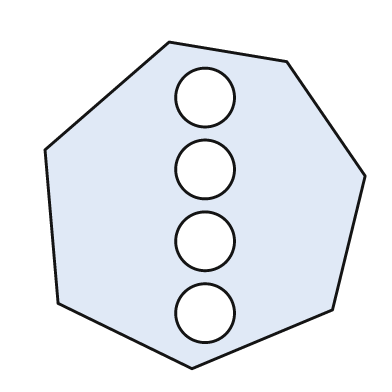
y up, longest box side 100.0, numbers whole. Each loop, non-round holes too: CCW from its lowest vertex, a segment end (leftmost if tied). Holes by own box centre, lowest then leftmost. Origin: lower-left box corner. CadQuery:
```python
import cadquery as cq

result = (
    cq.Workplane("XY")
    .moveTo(45.0, 0.0)
    .lineTo(88.0, 18.0)
    .lineTo(98.0, 59.0)
    .lineTo(74.0, 94.0)
    .lineTo(38.0, 100.0)
    .lineTo(0.0, 67.0)
    .lineTo(4.0, 20.0)
    .close()
    .moveTo(49.0, 17.0)
    .circle(9.0)
    .moveTo(49.0, 39.0)
    .circle(9.0)
    .moveTo(49.0, 61.0)
    .circle(9.0)
    .moveTo(49.0, 83.0)
    .circle(9.0)
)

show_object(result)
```